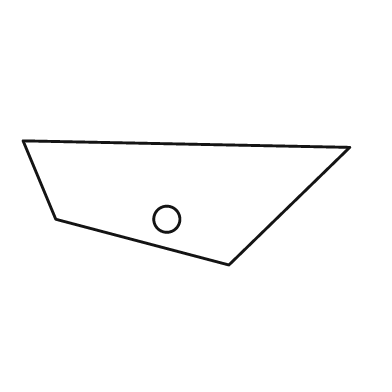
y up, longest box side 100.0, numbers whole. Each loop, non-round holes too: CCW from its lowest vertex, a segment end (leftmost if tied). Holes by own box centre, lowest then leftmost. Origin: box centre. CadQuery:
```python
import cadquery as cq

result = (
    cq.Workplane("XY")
    .moveTo(13.0, -19.0)
    .lineTo(50.0, 17.0)
    .lineTo(-50.0, 19.0)
    .lineTo(-40.0, -5.0)
    .close()
    .moveTo(-6.0, -5.0)
    .circle(4.0)
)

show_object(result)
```